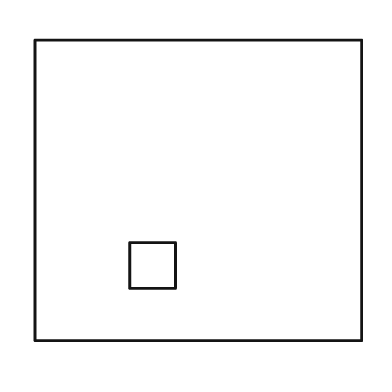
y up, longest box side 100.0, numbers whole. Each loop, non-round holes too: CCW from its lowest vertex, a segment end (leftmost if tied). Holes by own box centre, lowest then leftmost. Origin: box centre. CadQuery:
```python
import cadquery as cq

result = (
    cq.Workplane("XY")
    .moveTo(-50.0, -46.0)
    .lineTo(50.0, -46.0)
    .lineTo(50.0, 46.0)
    .lineTo(-50.0, 46.0)
    .close()
    .moveTo(-21.0, -30.0)
    .lineTo(-7.0, -30.0)
    .lineTo(-7.0, -16.0)
    .lineTo(-21.0, -16.0)
    .close()
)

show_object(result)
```